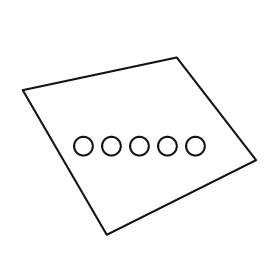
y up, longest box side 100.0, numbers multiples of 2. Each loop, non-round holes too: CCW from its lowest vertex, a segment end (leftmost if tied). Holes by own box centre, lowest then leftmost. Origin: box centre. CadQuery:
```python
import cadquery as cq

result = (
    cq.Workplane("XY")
    .moveTo(-14.0, -38.0)
    .lineTo(50.0, -6.0)
    .lineTo(16.0, 38.0)
    .lineTo(-50.0, 24.0)
    .close()
    .moveTo(-24.0, 0.0)
    .circle(4.0)
    .moveTo(-12.0, 0.0)
    .circle(4.0)
    .moveTo(0.0, 0.0)
    .circle(4.0)
    .moveTo(12.0, 0.0)
    .circle(4.0)
    .moveTo(24.0, 0.0)
    .circle(4.0)
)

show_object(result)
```